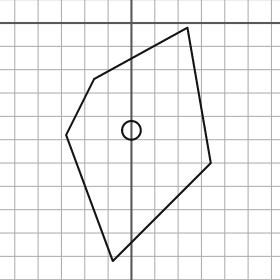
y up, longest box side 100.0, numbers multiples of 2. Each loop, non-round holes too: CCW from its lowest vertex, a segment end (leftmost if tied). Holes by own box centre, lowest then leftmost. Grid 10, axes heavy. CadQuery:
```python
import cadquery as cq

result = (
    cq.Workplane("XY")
    .moveTo(-8.0, -102.0)
    .lineTo(34.0, -60.0)
    .lineTo(24.0, -2.0)
    .lineTo(-16.0, -24.0)
    .lineTo(-28.0, -48.0)
    .close()
    .moveTo(0.0, -46.0)
    .circle(4.0)
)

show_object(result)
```